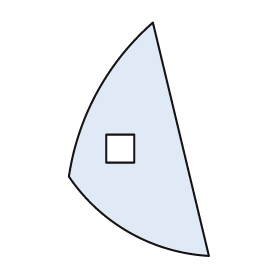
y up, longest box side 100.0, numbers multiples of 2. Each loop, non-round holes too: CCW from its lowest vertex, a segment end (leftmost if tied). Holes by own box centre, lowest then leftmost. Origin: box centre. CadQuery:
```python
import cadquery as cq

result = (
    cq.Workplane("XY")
    .moveTo(30.0, -50.0)
    .lineTo(6.0, 50.0)
    .threePointArc((-18.0, 20.0), (-30.0, -16.0))
    .threePointArc((-4.0, -40.0), (30.0, -50.0))
    .close()
    .moveTo(-14.0, -10.0)
    .lineTo(-2.0, -10.0)
    .lineTo(-2.0, 2.0)
    .lineTo(-14.0, 2.0)
    .close()
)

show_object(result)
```